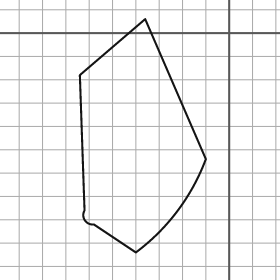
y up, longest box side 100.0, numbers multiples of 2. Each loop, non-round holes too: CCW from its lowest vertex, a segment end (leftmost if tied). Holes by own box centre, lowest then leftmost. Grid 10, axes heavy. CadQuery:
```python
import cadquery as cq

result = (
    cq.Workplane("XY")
    .moveTo(-40.0, -94.0)
    .threePointArc((-22.0, -76.0), (-10.0, -54.0))
    .lineTo(-36.0, 6.0)
    .lineTo(-64.0, -18.0)
    .lineTo(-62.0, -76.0)
    .threePointArc((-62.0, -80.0), (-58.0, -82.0))
    .close()
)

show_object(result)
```